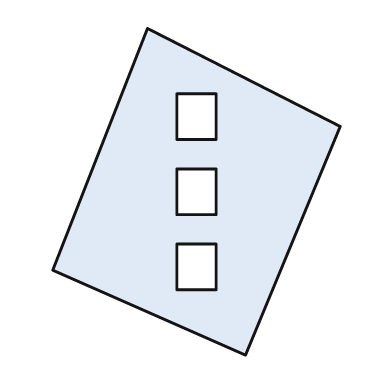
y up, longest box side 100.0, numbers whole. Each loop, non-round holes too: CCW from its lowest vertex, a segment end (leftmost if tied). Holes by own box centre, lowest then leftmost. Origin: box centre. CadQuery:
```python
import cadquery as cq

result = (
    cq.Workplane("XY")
    .moveTo(15.0, -50.0)
    .lineTo(44.0, 20.0)
    .lineTo(-15.0, 50.0)
    .lineTo(-44.0, -24.0)
    .close()
    .moveTo(-6.0, -30.0)
    .lineTo(6.0, -30.0)
    .lineTo(6.0, -16.0)
    .lineTo(-6.0, -16.0)
    .close()
    .moveTo(-6.0, -7.0)
    .lineTo(6.0, -7.0)
    .lineTo(6.0, 7.0)
    .lineTo(-6.0, 7.0)
    .close()
    .moveTo(-6.0, 16.0)
    .lineTo(6.0, 16.0)
    .lineTo(6.0, 30.0)
    .lineTo(-6.0, 30.0)
    .close()
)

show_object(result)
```